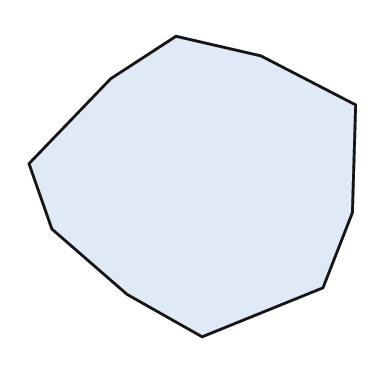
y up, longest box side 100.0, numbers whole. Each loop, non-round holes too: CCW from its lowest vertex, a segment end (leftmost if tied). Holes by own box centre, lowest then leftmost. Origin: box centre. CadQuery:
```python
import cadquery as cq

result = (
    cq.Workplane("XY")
    .moveTo(3.0, -46.0)
    .lineTo(40.0, -31.0)
    .lineTo(49.0, -8.0)
    .lineTo(50.0, 25.0)
    .lineTo(21.0, 40.0)
    .lineTo(-5.0, 46.0)
    .lineTo(-25.0, 33.0)
    .lineTo(-50.0, 7.0)
    .lineTo(-43.0, -13.0)
    .lineTo(-20.0, -33.0)
    .close()
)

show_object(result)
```